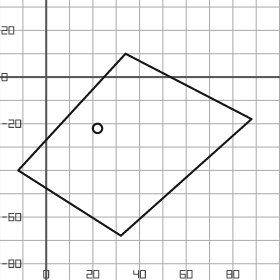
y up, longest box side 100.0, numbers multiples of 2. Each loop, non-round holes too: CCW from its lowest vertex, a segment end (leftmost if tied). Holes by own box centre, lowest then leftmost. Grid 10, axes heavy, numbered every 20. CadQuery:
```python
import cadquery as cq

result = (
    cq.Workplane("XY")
    .moveTo(32.0, -68.0)
    .lineTo(88.0, -18.0)
    .lineTo(34.0, 10.0)
    .lineTo(-12.0, -40.0)
    .close()
    .moveTo(22.0, -22.0)
    .circle(2.0)
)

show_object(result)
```